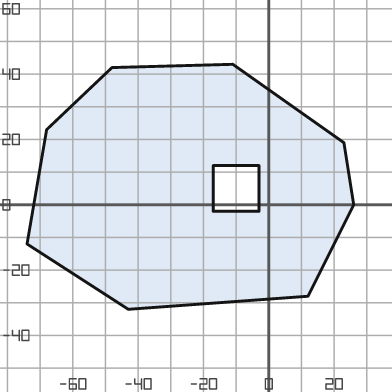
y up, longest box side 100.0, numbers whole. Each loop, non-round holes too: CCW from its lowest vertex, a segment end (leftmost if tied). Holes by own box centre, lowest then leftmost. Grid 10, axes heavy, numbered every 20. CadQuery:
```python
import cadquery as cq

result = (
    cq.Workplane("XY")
    .moveTo(-43.0, -32.0)
    .lineTo(12.0, -28.0)
    .lineTo(26.0, 0.0)
    .lineTo(23.0, 19.0)
    .lineTo(-11.0, 43.0)
    .lineTo(-48.0, 42.0)
    .lineTo(-68.0, 23.0)
    .lineTo(-74.0, -12.0)
    .close()
    .moveTo(-17.0, -2.0)
    .lineTo(-3.0, -2.0)
    .lineTo(-3.0, 12.0)
    .lineTo(-17.0, 12.0)
    .close()
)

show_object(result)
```